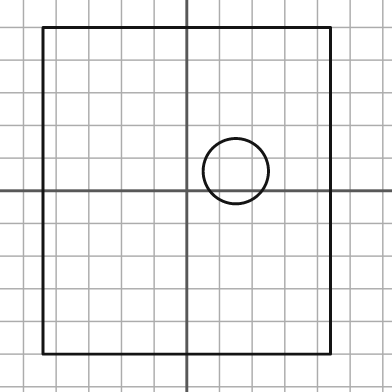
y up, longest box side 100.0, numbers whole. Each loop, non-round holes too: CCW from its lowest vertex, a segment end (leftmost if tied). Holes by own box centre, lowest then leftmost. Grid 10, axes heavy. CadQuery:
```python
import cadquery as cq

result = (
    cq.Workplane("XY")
    .moveTo(-44.0, -50.0)
    .lineTo(44.0, -50.0)
    .lineTo(44.0, 50.0)
    .lineTo(-44.0, 50.0)
    .close()
    .moveTo(15.0, 6.0)
    .circle(10.0)
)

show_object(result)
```